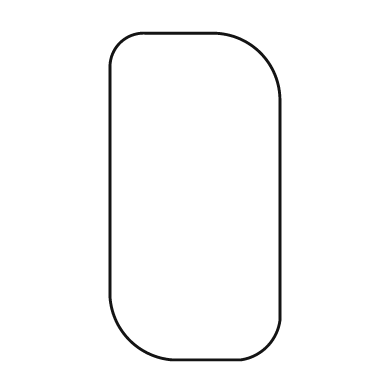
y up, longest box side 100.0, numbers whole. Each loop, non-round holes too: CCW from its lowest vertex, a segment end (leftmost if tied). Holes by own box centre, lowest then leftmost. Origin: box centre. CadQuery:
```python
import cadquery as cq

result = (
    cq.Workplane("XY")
    .moveTo(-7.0, -50.0)
    .lineTo(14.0, -50.0)
    .threePointArc((22.0, -46.0), (26.0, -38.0))
    .lineTo(26.0, 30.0)
    .threePointArc((20.0, 44.0), (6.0, 50.0))
    .lineTo(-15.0, 50.0)
    .threePointArc((-23.0, 47.0), (-26.0, 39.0))
    .lineTo(-26.0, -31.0)
    .threePointArc((-20.0, -44.0), (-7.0, -50.0))
    .close()
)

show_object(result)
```